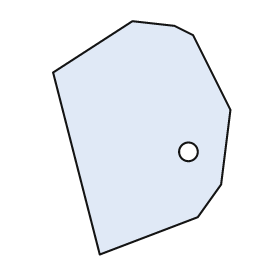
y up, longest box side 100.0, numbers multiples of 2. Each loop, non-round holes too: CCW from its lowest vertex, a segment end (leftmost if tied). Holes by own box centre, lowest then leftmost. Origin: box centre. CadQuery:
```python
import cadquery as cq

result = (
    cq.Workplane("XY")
    .moveTo(-18.0, -50.0)
    .lineTo(24.0, -34.0)
    .lineTo(34.0, -20.0)
    .lineTo(38.0, 12.0)
    .lineTo(22.0, 44.0)
    .lineTo(14.0, 48.0)
    .lineTo(-4.0, 50.0)
    .lineTo(-38.0, 28.0)
    .close()
    .moveTo(20.0, -6.0)
    .circle(4.0)
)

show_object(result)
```